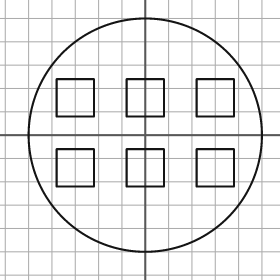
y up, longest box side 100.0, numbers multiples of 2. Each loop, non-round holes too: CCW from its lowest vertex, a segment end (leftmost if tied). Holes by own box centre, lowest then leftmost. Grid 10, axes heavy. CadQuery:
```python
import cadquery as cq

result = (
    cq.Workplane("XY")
    .moveTo(0.0, 0.0)
    .circle(50.0)
    .moveTo(-38.0, -22.0)
    .lineTo(-22.0, -22.0)
    .lineTo(-22.0, -6.0)
    .lineTo(-38.0, -6.0)
    .close()
    .moveTo(-8.0, -22.0)
    .lineTo(8.0, -22.0)
    .lineTo(8.0, -6.0)
    .lineTo(-8.0, -6.0)
    .close()
    .moveTo(22.0, -22.0)
    .lineTo(38.0, -22.0)
    .lineTo(38.0, -6.0)
    .lineTo(22.0, -6.0)
    .close()
    .moveTo(-38.0, 8.0)
    .lineTo(-22.0, 8.0)
    .lineTo(-22.0, 24.0)
    .lineTo(-38.0, 24.0)
    .close()
    .moveTo(-8.0, 8.0)
    .lineTo(8.0, 8.0)
    .lineTo(8.0, 24.0)
    .lineTo(-8.0, 24.0)
    .close()
    .moveTo(22.0, 8.0)
    .lineTo(38.0, 8.0)
    .lineTo(38.0, 24.0)
    .lineTo(22.0, 24.0)
    .close()
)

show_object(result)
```